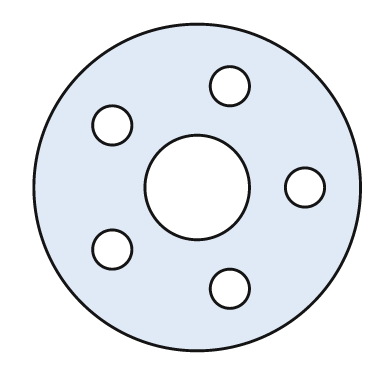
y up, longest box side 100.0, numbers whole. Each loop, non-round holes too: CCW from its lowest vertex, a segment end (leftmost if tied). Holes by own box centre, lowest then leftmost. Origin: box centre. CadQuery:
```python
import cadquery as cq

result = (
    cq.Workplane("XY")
    .moveTo(0.0, 0.0)
    .circle(50.0)
    .moveTo(10.0, -31.0)
    .circle(6.0)
    .moveTo(-26.0, -19.0)
    .circle(6.0)
    .moveTo(0.0, 0.0)
    .circle(16.0)
    .moveTo(33.0, 0.0)
    .circle(6.0)
    .moveTo(-26.0, 19.0)
    .circle(6.0)
    .moveTo(10.0, 31.0)
    .circle(6.0)
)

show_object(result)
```